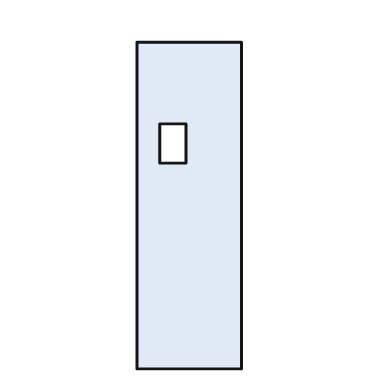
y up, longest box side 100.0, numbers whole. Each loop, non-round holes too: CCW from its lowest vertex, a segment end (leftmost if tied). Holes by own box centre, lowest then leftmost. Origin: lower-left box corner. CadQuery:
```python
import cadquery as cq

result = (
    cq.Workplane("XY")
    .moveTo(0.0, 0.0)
    .lineTo(32.0, 0.0)
    .lineTo(32.0, 100.0)
    .lineTo(0.0, 100.0)
    .close()
    .moveTo(7.0, 63.0)
    .lineTo(15.0, 63.0)
    .lineTo(15.0, 75.0)
    .lineTo(7.0, 75.0)
    .close()
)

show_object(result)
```